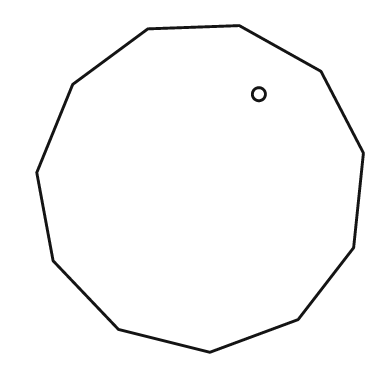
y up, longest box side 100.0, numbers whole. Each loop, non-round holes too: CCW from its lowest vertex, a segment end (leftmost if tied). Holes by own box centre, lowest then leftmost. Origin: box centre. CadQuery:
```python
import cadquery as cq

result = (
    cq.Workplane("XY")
    .moveTo(3.0, -50.0)
    .lineTo(30.0, -40.0)
    .lineTo(47.0, -18.0)
    .lineTo(50.0, 11.0)
    .lineTo(37.0, 36.0)
    .lineTo(12.0, 50.0)
    .lineTo(-16.0, 49.0)
    .lineTo(-39.0, 32.0)
    .lineTo(-50.0, 5.0)
    .lineTo(-45.0, -22.0)
    .lineTo(-25.0, -43.0)
    .close()
    .moveTo(18.0, 29.0)
    .circle(2.0)
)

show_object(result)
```